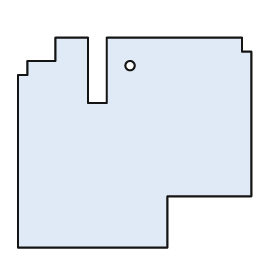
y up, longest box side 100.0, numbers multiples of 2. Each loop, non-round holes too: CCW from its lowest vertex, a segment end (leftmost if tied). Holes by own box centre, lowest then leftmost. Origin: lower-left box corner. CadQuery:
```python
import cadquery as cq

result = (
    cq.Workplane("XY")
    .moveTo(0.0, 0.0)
    .lineTo(64.0, 0.0)
    .lineTo(64.0, 22.0)
    .lineTo(100.0, 22.0)
    .lineTo(100.0, 84.0)
    .lineTo(96.0, 84.0)
    .lineTo(96.0, 90.0)
    .lineTo(38.0, 90.0)
    .lineTo(38.0, 62.0)
    .lineTo(30.0, 62.0)
    .lineTo(30.0, 90.0)
    .lineTo(16.0, 90.0)
    .lineTo(16.0, 80.0)
    .lineTo(4.0, 80.0)
    .lineTo(4.0, 74.0)
    .lineTo(0.0, 74.0)
    .close()
    .moveTo(48.0, 78.0)
    .circle(2.0)
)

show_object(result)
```